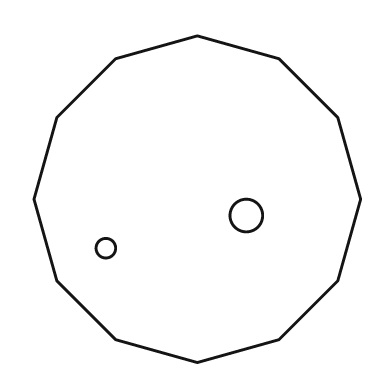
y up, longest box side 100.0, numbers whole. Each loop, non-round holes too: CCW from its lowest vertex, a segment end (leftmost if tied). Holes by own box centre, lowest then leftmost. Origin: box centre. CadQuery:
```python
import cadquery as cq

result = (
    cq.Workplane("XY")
    .moveTo(0.0, -50.0)
    .lineTo(25.0, -43.0)
    .lineTo(43.0, -25.0)
    .lineTo(50.0, 0.0)
    .lineTo(43.0, 25.0)
    .lineTo(25.0, 43.0)
    .lineTo(0.0, 50.0)
    .lineTo(-25.0, 43.0)
    .lineTo(-43.0, 25.0)
    .lineTo(-50.0, 0.0)
    .lineTo(-43.0, -25.0)
    .lineTo(-25.0, -43.0)
    .close()
    .moveTo(-28.0, -15.0)
    .circle(3.0)
    .moveTo(15.0, -5.0)
    .circle(5.0)
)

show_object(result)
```